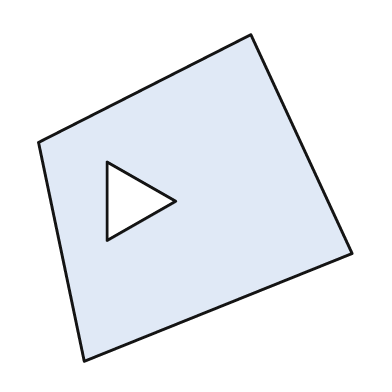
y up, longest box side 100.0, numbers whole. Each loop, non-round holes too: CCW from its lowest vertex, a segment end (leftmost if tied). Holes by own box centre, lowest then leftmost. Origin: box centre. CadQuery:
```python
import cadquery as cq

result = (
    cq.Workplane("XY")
    .moveTo(-34.0, -50.0)
    .lineTo(48.0, -17.0)
    .lineTo(17.0, 50.0)
    .lineTo(-48.0, 17.0)
    .close()
    .moveTo(-27.0, -13.0)
    .lineTo(-6.0, -1.0)
    .lineTo(-27.0, 11.0)
    .close()
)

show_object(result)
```